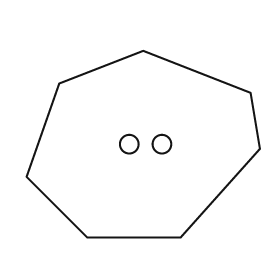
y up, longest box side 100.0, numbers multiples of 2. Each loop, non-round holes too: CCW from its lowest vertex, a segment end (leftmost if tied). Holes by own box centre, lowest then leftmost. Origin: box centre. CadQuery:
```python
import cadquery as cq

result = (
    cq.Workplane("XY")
    .moveTo(-24.0, -40.0)
    .lineTo(16.0, -40.0)
    .lineTo(50.0, -2.0)
    .lineTo(46.0, 22.0)
    .lineTo(0.0, 40.0)
    .lineTo(-36.0, 26.0)
    .lineTo(-50.0, -14.0)
    .close()
    .moveTo(-6.0, 0.0)
    .circle(4.0)
    .moveTo(8.0, 0.0)
    .circle(4.0)
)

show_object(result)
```